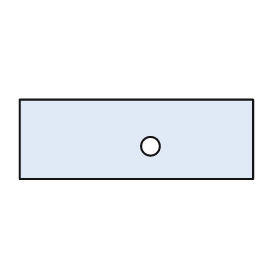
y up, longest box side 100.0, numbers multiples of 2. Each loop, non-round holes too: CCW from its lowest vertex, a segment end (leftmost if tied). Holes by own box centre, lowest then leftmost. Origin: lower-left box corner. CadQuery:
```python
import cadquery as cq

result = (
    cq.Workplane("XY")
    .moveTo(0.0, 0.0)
    .lineTo(100.0, 0.0)
    .lineTo(100.0, 34.0)
    .lineTo(0.0, 34.0)
    .close()
    .moveTo(56.0, 14.0)
    .circle(4.0)
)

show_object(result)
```